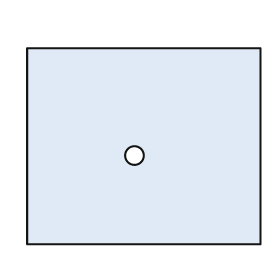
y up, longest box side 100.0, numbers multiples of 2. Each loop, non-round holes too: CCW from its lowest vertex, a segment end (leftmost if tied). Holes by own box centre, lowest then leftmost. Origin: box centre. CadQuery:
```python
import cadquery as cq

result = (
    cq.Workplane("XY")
    .moveTo(-50.0, -42.0)
    .lineTo(50.0, -42.0)
    .lineTo(50.0, 42.0)
    .lineTo(-50.0, 42.0)
    .close()
    .moveTo(-4.0, -4.0)
    .circle(4.0)
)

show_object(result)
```